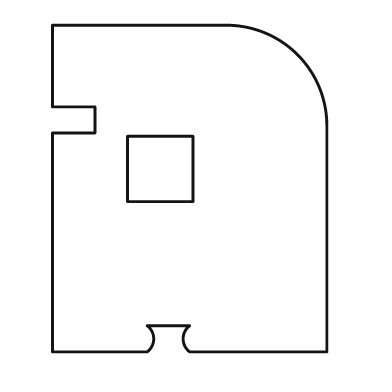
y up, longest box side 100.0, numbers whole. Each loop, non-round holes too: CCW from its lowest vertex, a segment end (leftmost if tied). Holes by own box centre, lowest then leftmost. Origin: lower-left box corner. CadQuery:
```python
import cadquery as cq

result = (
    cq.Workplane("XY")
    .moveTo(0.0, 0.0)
    .lineTo(29.0, 0.0)
    .threePointArc((31.0, 4.0), (29.0, 8.0))
    .lineTo(42.0, 8.0)
    .threePointArc((40.0, 4.0), (42.0, 0.0))
    .lineTo(84.0, 0.0)
    .lineTo(84.0, 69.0)
    .threePointArc((75.0, 91.0), (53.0, 100.0))
    .lineTo(0.0, 100.0)
    .lineTo(0.0, 75.0)
    .lineTo(13.0, 75.0)
    .lineTo(13.0, 67.0)
    .lineTo(0.0, 67.0)
    .close()
    .moveTo(23.0, 46.0)
    .lineTo(43.0, 46.0)
    .lineTo(43.0, 66.0)
    .lineTo(23.0, 66.0)
    .close()
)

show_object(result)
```